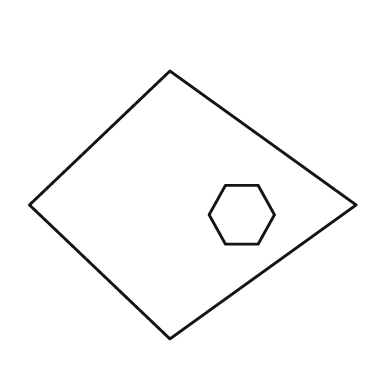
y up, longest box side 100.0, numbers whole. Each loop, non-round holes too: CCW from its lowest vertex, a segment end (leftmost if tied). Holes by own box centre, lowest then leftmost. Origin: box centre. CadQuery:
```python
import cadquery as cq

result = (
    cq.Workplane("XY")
    .moveTo(-7.0, -41.0)
    .lineTo(50.0, 0.0)
    .lineTo(-7.0, 41.0)
    .lineTo(-50.0, 0.0)
    .close()
    .moveTo(10.0, -12.0)
    .lineTo(20.0, -12.0)
    .lineTo(25.0, -3.0)
    .lineTo(20.0, 6.0)
    .lineTo(10.0, 6.0)
    .lineTo(5.0, -3.0)
    .close()
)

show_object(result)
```